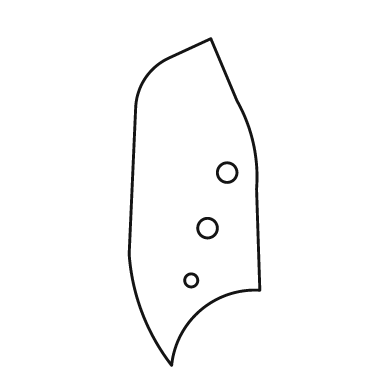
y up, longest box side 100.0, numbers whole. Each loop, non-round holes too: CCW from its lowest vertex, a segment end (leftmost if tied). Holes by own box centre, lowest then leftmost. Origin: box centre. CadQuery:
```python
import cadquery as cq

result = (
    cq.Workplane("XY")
    .moveTo(-7.0, -50.0)
    .threePointArc((2.0, -33.0), (20.0, -27.0))
    .lineTo(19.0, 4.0)
    .threePointArc((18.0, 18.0), (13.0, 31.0))
    .lineTo(5.0, 50.0)
    .lineTo(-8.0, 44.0)
    .threePointArc((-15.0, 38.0), (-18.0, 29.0))
    .lineTo(-20.0, -16.0)
    .threePointArc((-16.0, -34.0), (-7.0, -50.0))
    .close()
    .moveTo(-1.0, -24.0)
    .circle(2.0)
    .moveTo(4.0, -8.0)
    .circle(3.0)
    .moveTo(10.0, 9.0)
    .circle(3.0)
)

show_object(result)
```